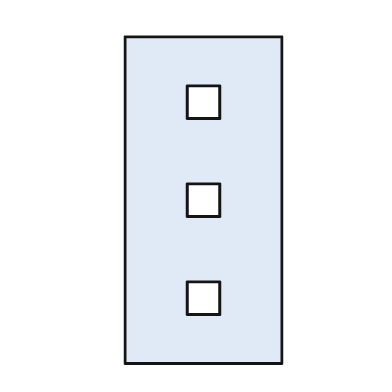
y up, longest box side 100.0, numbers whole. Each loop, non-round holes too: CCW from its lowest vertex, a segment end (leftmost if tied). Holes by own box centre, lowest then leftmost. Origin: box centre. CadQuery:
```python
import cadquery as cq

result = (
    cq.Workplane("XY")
    .moveTo(-24.0, -50.0)
    .lineTo(24.0, -50.0)
    .lineTo(24.0, 50.0)
    .lineTo(-24.0, 50.0)
    .close()
    .moveTo(-5.0, -35.0)
    .lineTo(5.0, -35.0)
    .lineTo(5.0, -25.0)
    .lineTo(-5.0, -25.0)
    .close()
    .moveTo(-5.0, -5.0)
    .lineTo(5.0, -5.0)
    .lineTo(5.0, 5.0)
    .lineTo(-5.0, 5.0)
    .close()
    .moveTo(-5.0, 25.0)
    .lineTo(5.0, 25.0)
    .lineTo(5.0, 35.0)
    .lineTo(-5.0, 35.0)
    .close()
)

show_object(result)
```